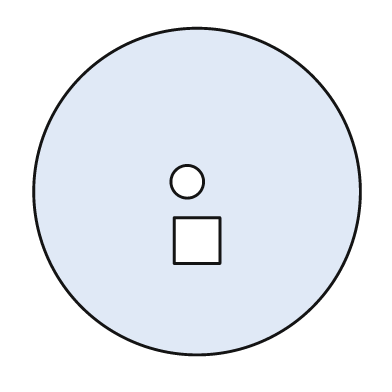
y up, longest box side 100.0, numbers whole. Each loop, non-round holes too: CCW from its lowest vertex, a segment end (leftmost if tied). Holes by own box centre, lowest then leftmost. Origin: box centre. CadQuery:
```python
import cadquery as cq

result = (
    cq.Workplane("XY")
    .moveTo(0.0, 0.0)
    .circle(50.0)
    .moveTo(-7.0, -22.0)
    .lineTo(7.0, -22.0)
    .lineTo(7.0, -8.0)
    .lineTo(-7.0, -8.0)
    .close()
    .moveTo(-3.0, 3.0)
    .circle(5.0)
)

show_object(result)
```